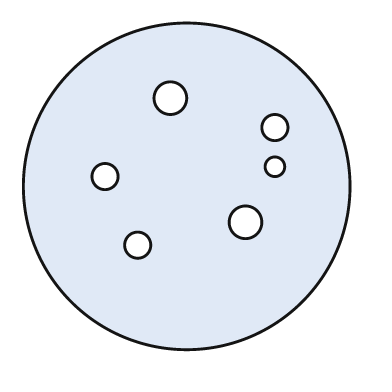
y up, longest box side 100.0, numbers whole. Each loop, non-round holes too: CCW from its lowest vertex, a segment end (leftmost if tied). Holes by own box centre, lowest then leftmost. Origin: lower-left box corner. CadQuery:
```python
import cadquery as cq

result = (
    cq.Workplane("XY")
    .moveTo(50.0, 50.0)
    .circle(50.0)
    .moveTo(35.0, 32.0)
    .circle(4.0)
    .moveTo(68.0, 39.0)
    .circle(5.0)
    .moveTo(25.0, 53.0)
    .circle(4.0)
    .moveTo(77.0, 56.0)
    .circle(3.0)
    .moveTo(77.0, 68.0)
    .circle(4.0)
    .moveTo(45.0, 77.0)
    .circle(5.0)
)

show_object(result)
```